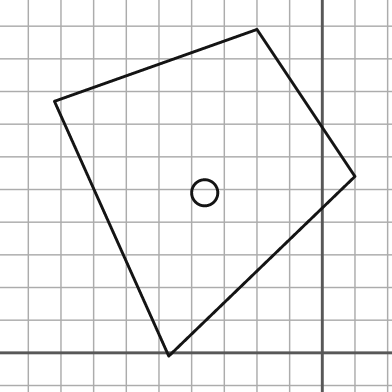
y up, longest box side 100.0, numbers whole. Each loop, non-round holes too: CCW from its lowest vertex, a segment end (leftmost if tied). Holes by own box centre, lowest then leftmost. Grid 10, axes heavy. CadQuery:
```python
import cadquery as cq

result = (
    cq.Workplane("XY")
    .moveTo(-47.0, -1.0)
    .lineTo(10.0, 54.0)
    .lineTo(-20.0, 99.0)
    .lineTo(-82.0, 77.0)
    .close()
    .moveTo(-36.0, 49.0)
    .circle(4.0)
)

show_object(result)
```